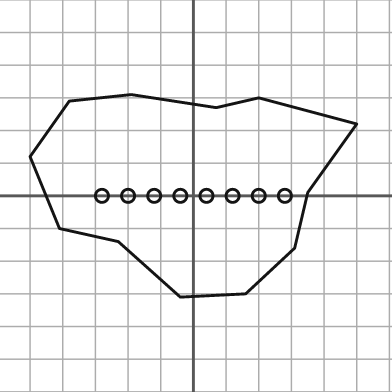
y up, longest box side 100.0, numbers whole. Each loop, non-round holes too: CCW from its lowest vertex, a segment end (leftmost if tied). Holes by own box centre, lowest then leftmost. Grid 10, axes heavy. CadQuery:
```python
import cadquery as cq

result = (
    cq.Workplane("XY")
    .moveTo(-4.0, -31.0)
    .lineTo(16.0, -30.0)
    .lineTo(31.0, -16.0)
    .lineTo(35.0, 1.0)
    .lineTo(50.0, 22.0)
    .lineTo(20.0, 30.0)
    .lineTo(7.0, 27.0)
    .lineTo(-19.0, 31.0)
    .lineTo(-38.0, 29.0)
    .lineTo(-50.0, 12.0)
    .lineTo(-41.0, -10.0)
    .lineTo(-23.0, -14.0)
    .close()
    .moveTo(-28.0, 0.0)
    .circle(2.0)
    .moveTo(-20.0, 0.0)
    .circle(2.0)
    .moveTo(-12.0, 0.0)
    .circle(2.0)
    .moveTo(-4.0, 0.0)
    .circle(2.0)
    .moveTo(4.0, 0.0)
    .circle(2.0)
    .moveTo(12.0, 0.0)
    .circle(2.0)
    .moveTo(20.0, 0.0)
    .circle(2.0)
    .moveTo(28.0, 0.0)
    .circle(2.0)
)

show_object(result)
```